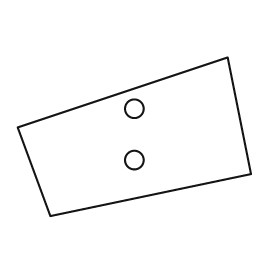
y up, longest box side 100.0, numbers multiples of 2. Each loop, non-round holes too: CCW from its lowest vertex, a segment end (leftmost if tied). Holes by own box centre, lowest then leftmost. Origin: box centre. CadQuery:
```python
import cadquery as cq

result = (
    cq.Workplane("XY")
    .moveTo(-36.0, -34.0)
    .lineTo(50.0, -16.0)
    .lineTo(40.0, 34.0)
    .lineTo(-50.0, 4.0)
    .close()
    .moveTo(0.0, -10.0)
    .circle(4.0)
    .moveTo(0.0, 12.0)
    .circle(4.0)
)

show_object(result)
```